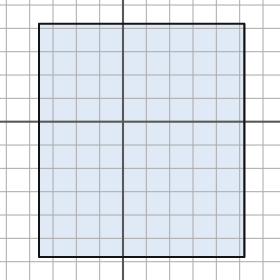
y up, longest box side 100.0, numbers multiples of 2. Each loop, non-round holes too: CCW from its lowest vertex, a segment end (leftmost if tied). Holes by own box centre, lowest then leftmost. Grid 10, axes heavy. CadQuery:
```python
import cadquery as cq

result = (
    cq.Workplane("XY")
    .moveTo(-36.0, -58.0)
    .lineTo(52.0, -58.0)
    .lineTo(52.0, 42.0)
    .lineTo(-36.0, 42.0)
    .close()
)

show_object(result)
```